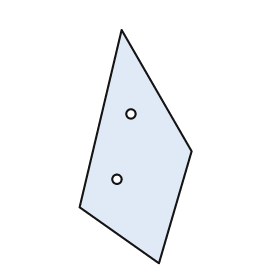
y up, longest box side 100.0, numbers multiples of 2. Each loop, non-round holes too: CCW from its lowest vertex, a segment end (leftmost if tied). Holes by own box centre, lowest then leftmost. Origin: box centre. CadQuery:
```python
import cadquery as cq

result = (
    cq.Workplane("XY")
    .moveTo(10.0, -50.0)
    .lineTo(24.0, -2.0)
    .lineTo(-6.0, 50.0)
    .lineTo(-24.0, -26.0)
    .close()
    .moveTo(-8.0, -14.0)
    .circle(2.0)
    .moveTo(-2.0, 14.0)
    .circle(2.0)
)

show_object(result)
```